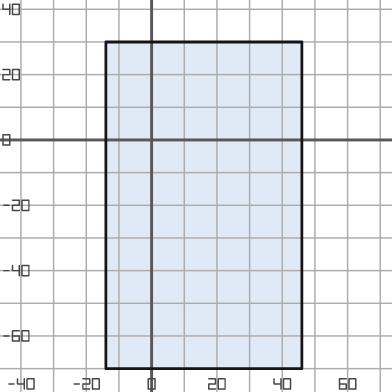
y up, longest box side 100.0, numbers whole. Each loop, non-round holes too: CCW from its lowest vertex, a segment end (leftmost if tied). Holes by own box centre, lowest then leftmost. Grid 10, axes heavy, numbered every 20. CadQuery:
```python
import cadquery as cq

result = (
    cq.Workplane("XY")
    .moveTo(-14.0, -70.0)
    .lineTo(46.0, -70.0)
    .lineTo(46.0, 30.0)
    .lineTo(-14.0, 30.0)
    .close()
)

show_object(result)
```